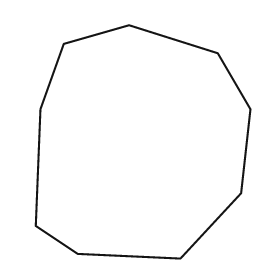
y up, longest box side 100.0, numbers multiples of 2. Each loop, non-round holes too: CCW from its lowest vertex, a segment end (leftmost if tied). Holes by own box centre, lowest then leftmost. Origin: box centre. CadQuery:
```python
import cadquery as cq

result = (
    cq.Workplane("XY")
    .moveTo(16.0, -50.0)
    .lineTo(42.0, -22.0)
    .lineTo(46.0, 14.0)
    .lineTo(32.0, 38.0)
    .lineTo(-6.0, 50.0)
    .lineTo(-34.0, 42.0)
    .lineTo(-44.0, 14.0)
    .lineTo(-46.0, -36.0)
    .lineTo(-28.0, -48.0)
    .close()
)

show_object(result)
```